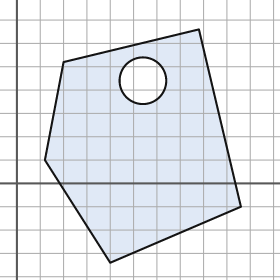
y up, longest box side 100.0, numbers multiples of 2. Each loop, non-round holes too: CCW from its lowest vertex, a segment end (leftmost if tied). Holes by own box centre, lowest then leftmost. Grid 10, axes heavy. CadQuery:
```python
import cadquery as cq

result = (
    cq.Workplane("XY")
    .moveTo(40.0, -34.0)
    .lineTo(96.0, -10.0)
    .lineTo(78.0, 66.0)
    .lineTo(20.0, 52.0)
    .lineTo(12.0, 10.0)
    .close()
    .moveTo(54.0, 44.0)
    .circle(10.0)
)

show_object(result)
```